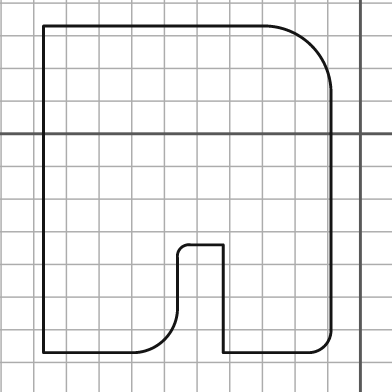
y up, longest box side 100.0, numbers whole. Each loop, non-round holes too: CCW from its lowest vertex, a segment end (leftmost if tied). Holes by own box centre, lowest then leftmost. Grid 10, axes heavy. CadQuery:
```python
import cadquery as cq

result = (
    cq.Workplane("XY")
    .moveTo(-97.0, -67.0)
    .lineTo(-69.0, -67.0)
    .threePointArc((-60.0, -63.0), (-56.0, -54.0))
    .lineTo(-56.0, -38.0)
    .threePointArc((-55.0, -35.0), (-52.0, -34.0))
    .lineTo(-42.0, -34.0)
    .lineTo(-42.0, -67.0)
    .lineTo(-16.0, -67.0)
    .threePointArc((-11.0, -65.0), (-9.0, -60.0))
    .lineTo(-9.0, 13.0)
    .threePointArc((-15.0, 27.0), (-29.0, 33.0))
    .lineTo(-97.0, 33.0)
    .close()
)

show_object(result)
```